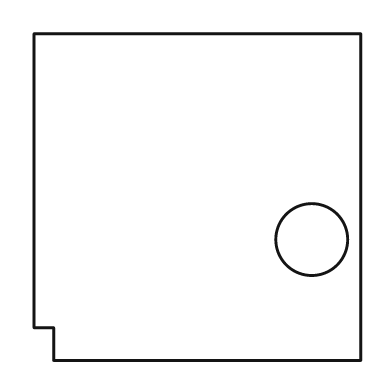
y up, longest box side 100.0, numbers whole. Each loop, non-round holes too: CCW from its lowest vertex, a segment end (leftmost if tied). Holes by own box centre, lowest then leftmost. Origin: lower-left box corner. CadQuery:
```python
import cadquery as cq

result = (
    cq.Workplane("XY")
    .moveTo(6.0, 0.0)
    .lineTo(100.0, 0.0)
    .lineTo(100.0, 100.0)
    .lineTo(0.0, 100.0)
    .lineTo(0.0, 10.0)
    .lineTo(6.0, 10.0)
    .close()
    .moveTo(85.0, 37.0)
    .circle(11.0)
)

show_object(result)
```